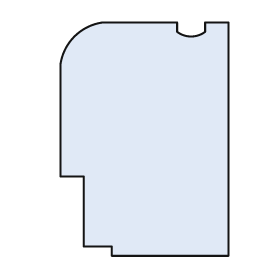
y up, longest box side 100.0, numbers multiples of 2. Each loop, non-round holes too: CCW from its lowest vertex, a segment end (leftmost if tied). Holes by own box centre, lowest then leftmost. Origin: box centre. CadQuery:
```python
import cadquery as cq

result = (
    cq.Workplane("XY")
    .moveTo(-14.0, -50.0)
    .lineTo(36.0, -50.0)
    .lineTo(36.0, 50.0)
    .lineTo(26.0, 50.0)
    .lineTo(26.0, 46.0)
    .threePointArc((20.0, 44.0), (14.0, 46.0))
    .lineTo(14.0, 50.0)
    .lineTo(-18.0, 50.0)
    .threePointArc((-30.0, 44.0), (-36.0, 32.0))
    .lineTo(-36.0, -16.0)
    .lineTo(-26.0, -16.0)
    .lineTo(-26.0, -46.0)
    .lineTo(-14.0, -46.0)
    .close()
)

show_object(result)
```